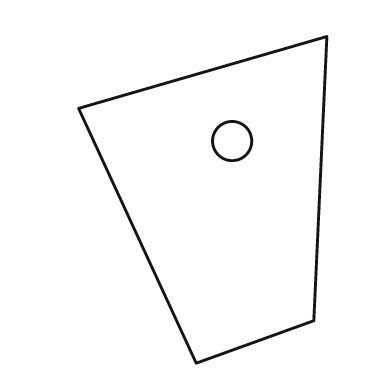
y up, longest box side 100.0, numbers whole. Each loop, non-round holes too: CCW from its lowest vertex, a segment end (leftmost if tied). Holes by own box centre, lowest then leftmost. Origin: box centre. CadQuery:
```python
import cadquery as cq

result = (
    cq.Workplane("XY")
    .moveTo(-2.0, -50.0)
    .lineTo(34.0, -37.0)
    .lineTo(38.0, 50.0)
    .lineTo(-38.0, 28.0)
    .close()
    .moveTo(9.0, 18.0)
    .circle(6.0)
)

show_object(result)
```